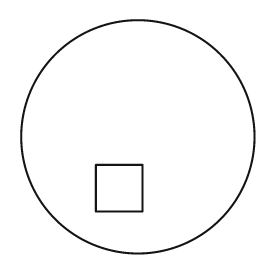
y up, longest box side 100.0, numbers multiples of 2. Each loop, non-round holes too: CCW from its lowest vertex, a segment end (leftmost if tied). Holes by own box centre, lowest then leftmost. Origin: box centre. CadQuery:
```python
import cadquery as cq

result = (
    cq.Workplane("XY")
    .moveTo(0.0, 0.0)
    .circle(50.0)
    .moveTo(-18.0, -32.0)
    .lineTo(2.0, -32.0)
    .lineTo(2.0, -12.0)
    .lineTo(-18.0, -12.0)
    .close()
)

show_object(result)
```